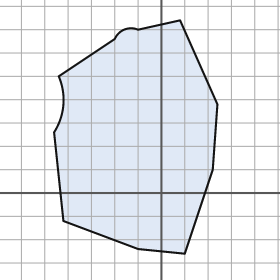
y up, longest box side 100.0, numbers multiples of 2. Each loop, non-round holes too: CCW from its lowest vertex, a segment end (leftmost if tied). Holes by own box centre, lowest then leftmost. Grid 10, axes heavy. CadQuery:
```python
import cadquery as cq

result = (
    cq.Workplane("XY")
    .moveTo(10.0, -26.0)
    .lineTo(22.0, 10.0)
    .lineTo(24.0, 38.0)
    .lineTo(8.0, 74.0)
    .lineTo(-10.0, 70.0)
    .threePointArc((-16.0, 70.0), (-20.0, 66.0))
    .lineTo(-44.0, 50.0)
    .threePointArc((-42.0, 38.0), (-46.0, 26.0))
    .lineTo(-42.0, -12.0)
    .lineTo(-10.0, -24.0)
    .close()
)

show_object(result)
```